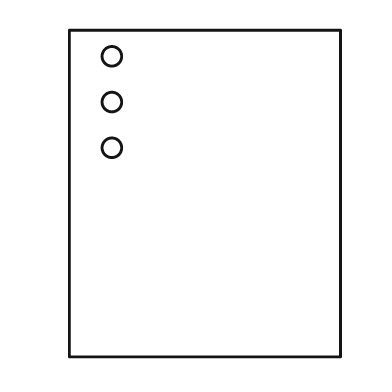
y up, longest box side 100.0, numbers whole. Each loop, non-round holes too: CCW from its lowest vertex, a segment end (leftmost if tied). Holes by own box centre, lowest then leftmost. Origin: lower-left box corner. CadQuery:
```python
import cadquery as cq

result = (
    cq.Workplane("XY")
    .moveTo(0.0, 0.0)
    .lineTo(83.0, 0.0)
    .lineTo(83.0, 100.0)
    .lineTo(0.0, 100.0)
    .close()
    .moveTo(13.0, 64.0)
    .circle(3.0)
    .moveTo(13.0, 78.0)
    .circle(3.0)
    .moveTo(13.0, 92.0)
    .circle(3.0)
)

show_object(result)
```